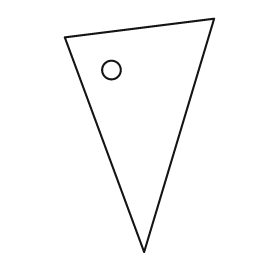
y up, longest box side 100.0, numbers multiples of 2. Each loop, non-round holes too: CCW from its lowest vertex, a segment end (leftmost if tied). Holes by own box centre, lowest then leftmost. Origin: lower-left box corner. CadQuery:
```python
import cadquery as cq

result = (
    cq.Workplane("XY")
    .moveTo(34.0, 0.0)
    .lineTo(64.0, 100.0)
    .lineTo(0.0, 92.0)
    .close()
    .moveTo(20.0, 78.0)
    .circle(4.0)
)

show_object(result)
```